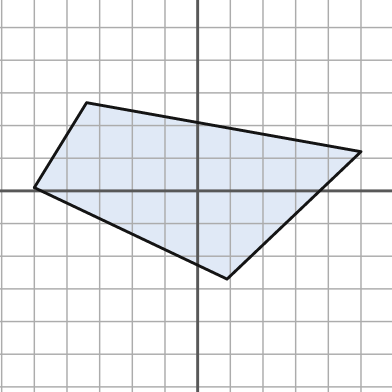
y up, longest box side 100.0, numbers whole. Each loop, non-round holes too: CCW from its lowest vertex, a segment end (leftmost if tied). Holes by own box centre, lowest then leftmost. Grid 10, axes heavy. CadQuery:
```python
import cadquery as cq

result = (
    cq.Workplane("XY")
    .moveTo(9.0, -27.0)
    .lineTo(50.0, 12.0)
    .lineTo(-34.0, 27.0)
    .lineTo(-50.0, 1.0)
    .close()
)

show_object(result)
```